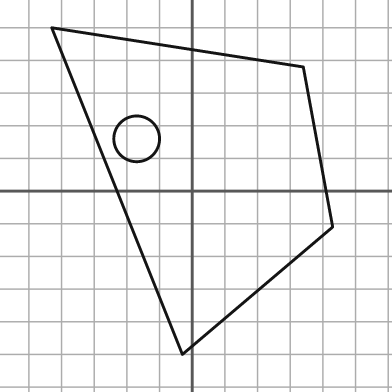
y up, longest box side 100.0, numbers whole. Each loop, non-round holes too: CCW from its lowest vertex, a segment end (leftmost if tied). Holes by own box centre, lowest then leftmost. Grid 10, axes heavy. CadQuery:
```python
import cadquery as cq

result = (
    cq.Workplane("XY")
    .moveTo(-3.0, -50.0)
    .lineTo(43.0, -11.0)
    .lineTo(34.0, 38.0)
    .lineTo(-43.0, 50.0)
    .close()
    .moveTo(-17.0, 16.0)
    .circle(7.0)
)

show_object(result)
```